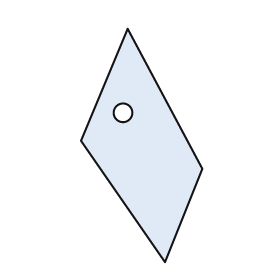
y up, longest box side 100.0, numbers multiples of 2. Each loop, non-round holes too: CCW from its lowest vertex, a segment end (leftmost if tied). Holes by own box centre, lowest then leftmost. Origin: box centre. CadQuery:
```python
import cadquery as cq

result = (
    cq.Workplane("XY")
    .moveTo(10.0, -50.0)
    .lineTo(26.0, -10.0)
    .lineTo(-6.0, 50.0)
    .lineTo(-26.0, 2.0)
    .close()
    .moveTo(-8.0, 14.0)
    .circle(4.0)
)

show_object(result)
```